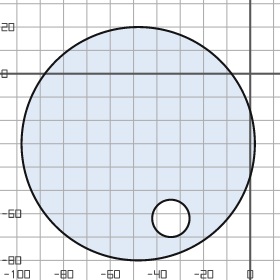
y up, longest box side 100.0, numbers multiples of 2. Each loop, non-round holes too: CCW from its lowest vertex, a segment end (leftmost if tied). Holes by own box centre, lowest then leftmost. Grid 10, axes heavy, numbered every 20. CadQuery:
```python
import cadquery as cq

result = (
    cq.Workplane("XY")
    .moveTo(-48.0, -30.0)
    .circle(50.0)
    .moveTo(-34.0, -62.0)
    .circle(8.0)
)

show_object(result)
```